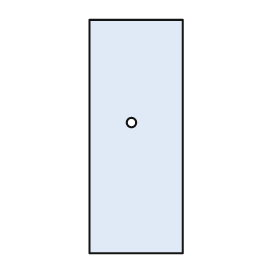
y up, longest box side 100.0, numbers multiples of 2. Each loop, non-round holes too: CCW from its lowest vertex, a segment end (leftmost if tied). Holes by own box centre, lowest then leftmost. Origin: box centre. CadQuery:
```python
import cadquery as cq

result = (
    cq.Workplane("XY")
    .moveTo(-20.0, -50.0)
    .lineTo(20.0, -50.0)
    .lineTo(20.0, 50.0)
    .lineTo(-20.0, 50.0)
    .close()
    .moveTo(-2.0, 6.0)
    .circle(2.0)
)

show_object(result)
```